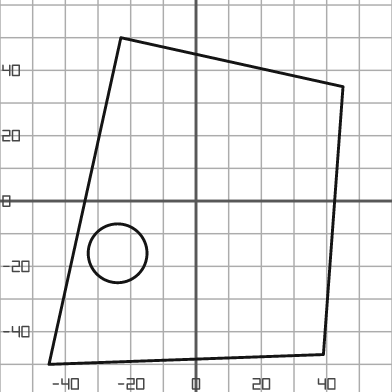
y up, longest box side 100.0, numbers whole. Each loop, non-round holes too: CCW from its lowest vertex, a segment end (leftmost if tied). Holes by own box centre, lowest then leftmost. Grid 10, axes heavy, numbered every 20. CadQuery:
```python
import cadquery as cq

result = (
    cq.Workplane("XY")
    .moveTo(-45.0, -50.0)
    .lineTo(39.0, -47.0)
    .lineTo(45.0, 35.0)
    .lineTo(-23.0, 50.0)
    .close()
    .moveTo(-24.0, -16.0)
    .circle(9.0)
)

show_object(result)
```